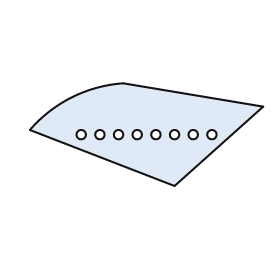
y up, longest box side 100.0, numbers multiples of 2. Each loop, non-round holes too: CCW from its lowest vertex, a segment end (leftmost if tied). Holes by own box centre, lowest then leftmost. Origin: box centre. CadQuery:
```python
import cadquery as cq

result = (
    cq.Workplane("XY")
    .moveTo(12.0, -22.0)
    .lineTo(50.0, 12.0)
    .lineTo(-10.0, 22.0)
    .threePointArc((-32.0, 16.0), (-50.0, 2.0))
    .close()
    .moveTo(-28.0, 0.0)
    .circle(2.0)
    .moveTo(-20.0, 0.0)
    .circle(2.0)
    .moveTo(-12.0, 0.0)
    .circle(2.0)
    .moveTo(-4.0, 0.0)
    .circle(2.0)
    .moveTo(4.0, 0.0)
    .circle(2.0)
    .moveTo(12.0, 0.0)
    .circle(2.0)
    .moveTo(20.0, 0.0)
    .circle(2.0)
    .moveTo(28.0, 0.0)
    .circle(2.0)
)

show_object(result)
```